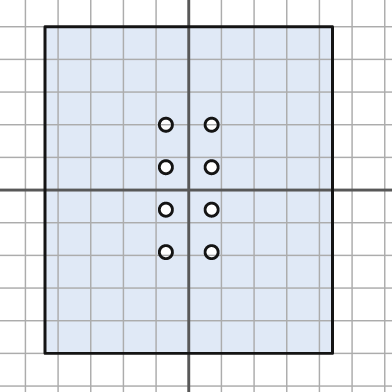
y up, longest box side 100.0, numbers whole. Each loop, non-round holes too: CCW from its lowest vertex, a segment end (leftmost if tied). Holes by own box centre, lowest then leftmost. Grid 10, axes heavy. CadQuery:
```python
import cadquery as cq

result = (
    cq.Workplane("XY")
    .moveTo(-44.0, -50.0)
    .lineTo(44.0, -50.0)
    .lineTo(44.0, 50.0)
    .lineTo(-44.0, 50.0)
    .close()
    .moveTo(-7.0, -19.0)
    .circle(2.0)
    .moveTo(7.0, -19.0)
    .circle(2.0)
    .moveTo(-7.0, -6.0)
    .circle(2.0)
    .moveTo(7.0, -6.0)
    .circle(2.0)
    .moveTo(-7.0, 7.0)
    .circle(2.0)
    .moveTo(7.0, 7.0)
    .circle(2.0)
    .moveTo(-7.0, 20.0)
    .circle(2.0)
    .moveTo(7.0, 20.0)
    .circle(2.0)
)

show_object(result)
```